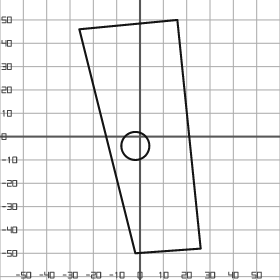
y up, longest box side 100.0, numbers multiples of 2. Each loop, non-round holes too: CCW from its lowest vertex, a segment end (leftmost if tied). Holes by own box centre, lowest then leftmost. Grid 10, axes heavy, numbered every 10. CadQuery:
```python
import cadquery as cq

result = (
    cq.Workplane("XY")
    .moveTo(-2.0, -50.0)
    .lineTo(26.0, -48.0)
    .lineTo(16.0, 50.0)
    .lineTo(-26.0, 46.0)
    .close()
    .moveTo(-2.0, -4.0)
    .circle(6.0)
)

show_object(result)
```